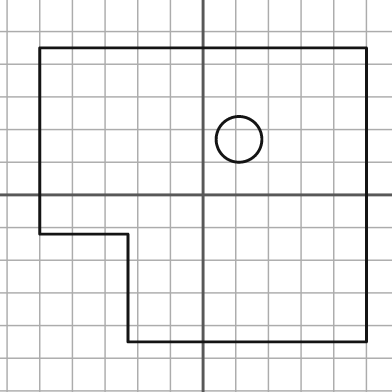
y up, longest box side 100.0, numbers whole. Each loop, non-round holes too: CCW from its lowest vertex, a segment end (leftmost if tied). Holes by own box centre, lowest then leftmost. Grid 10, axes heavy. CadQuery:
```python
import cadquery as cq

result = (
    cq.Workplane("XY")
    .moveTo(-23.0, -45.0)
    .lineTo(50.0, -45.0)
    .lineTo(50.0, 45.0)
    .lineTo(-50.0, 45.0)
    .lineTo(-50.0, -12.0)
    .lineTo(-23.0, -12.0)
    .close()
    .moveTo(11.0, 17.0)
    .circle(7.0)
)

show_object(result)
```